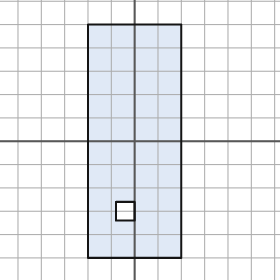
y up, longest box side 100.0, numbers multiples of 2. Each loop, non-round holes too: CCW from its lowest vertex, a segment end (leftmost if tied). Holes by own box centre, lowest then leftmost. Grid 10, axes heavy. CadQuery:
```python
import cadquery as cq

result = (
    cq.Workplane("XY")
    .moveTo(-20.0, -50.0)
    .lineTo(20.0, -50.0)
    .lineTo(20.0, 50.0)
    .lineTo(-20.0, 50.0)
    .close()
    .moveTo(-8.0, -34.0)
    .lineTo(0.0, -34.0)
    .lineTo(0.0, -26.0)
    .lineTo(-8.0, -26.0)
    .close()
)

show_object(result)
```